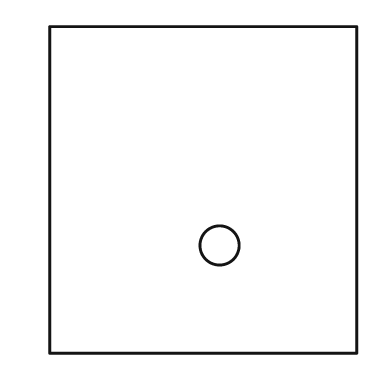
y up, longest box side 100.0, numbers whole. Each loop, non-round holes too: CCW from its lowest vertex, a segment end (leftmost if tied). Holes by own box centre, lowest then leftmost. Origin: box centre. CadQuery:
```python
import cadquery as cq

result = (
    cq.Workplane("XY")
    .moveTo(-47.0, -50.0)
    .lineTo(47.0, -50.0)
    .lineTo(47.0, 50.0)
    .lineTo(-47.0, 50.0)
    .close()
    .moveTo(5.0, -17.0)
    .circle(6.0)
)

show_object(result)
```